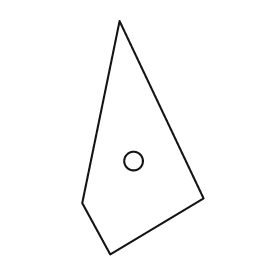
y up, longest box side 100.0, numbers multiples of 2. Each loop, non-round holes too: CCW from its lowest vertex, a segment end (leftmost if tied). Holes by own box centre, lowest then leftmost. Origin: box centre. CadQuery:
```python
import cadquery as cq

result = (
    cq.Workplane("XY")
    .moveTo(-14.0, -50.0)
    .lineTo(26.0, -26.0)
    .lineTo(-10.0, 50.0)
    .lineTo(-26.0, -28.0)
    .close()
    .moveTo(-4.0, -10.0)
    .circle(4.0)
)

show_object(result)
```